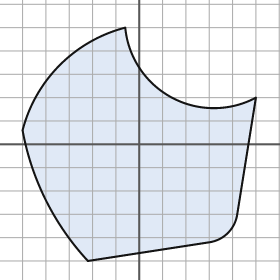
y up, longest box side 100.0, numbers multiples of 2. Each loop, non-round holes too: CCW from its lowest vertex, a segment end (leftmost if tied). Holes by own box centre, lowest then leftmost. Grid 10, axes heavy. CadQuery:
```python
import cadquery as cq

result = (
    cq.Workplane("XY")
    .moveTo(-22.0, -50.0)
    .lineTo(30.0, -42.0)
    .threePointArc((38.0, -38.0), (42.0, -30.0))
    .lineTo(50.0, 20.0)
    .threePointArc((14.0, 20.0), (-6.0, 50.0))
    .threePointArc((-34.0, 34.0), (-50.0, 6.0))
    .threePointArc((-40.0, -24.0), (-22.0, -50.0))
    .close()
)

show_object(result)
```